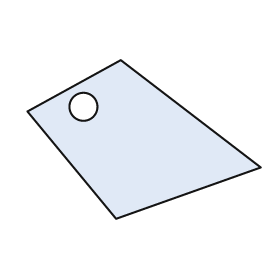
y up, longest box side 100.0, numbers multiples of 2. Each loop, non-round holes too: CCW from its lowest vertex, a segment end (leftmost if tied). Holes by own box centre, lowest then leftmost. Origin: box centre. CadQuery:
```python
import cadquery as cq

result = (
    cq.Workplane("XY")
    .moveTo(-12.0, -34.0)
    .lineTo(50.0, -12.0)
    .lineTo(-10.0, 34.0)
    .lineTo(-50.0, 12.0)
    .close()
    .moveTo(-26.0, 14.0)
    .circle(6.0)
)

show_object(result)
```